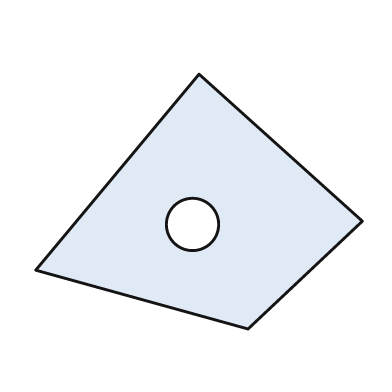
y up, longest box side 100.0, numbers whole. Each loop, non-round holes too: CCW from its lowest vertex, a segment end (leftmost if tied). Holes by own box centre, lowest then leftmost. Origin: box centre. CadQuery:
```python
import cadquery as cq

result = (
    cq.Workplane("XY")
    .moveTo(15.0, -39.0)
    .lineTo(50.0, -6.0)
    .lineTo(0.0, 39.0)
    .lineTo(-50.0, -21.0)
    .close()
    .moveTo(-2.0, -7.0)
    .circle(8.0)
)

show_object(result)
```